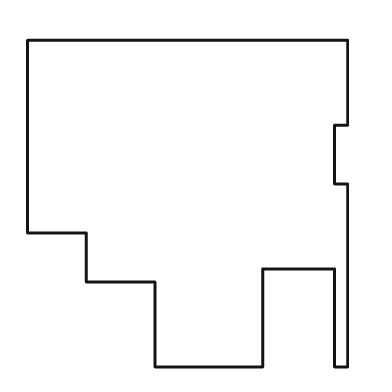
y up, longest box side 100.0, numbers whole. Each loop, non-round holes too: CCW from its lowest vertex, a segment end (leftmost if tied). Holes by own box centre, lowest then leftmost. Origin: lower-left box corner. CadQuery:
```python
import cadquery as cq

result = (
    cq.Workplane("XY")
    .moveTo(39.0, 0.0)
    .lineTo(72.0, 0.0)
    .lineTo(72.0, 30.0)
    .lineTo(94.0, 30.0)
    .lineTo(94.0, 0.0)
    .lineTo(98.0, 0.0)
    .lineTo(98.0, 56.0)
    .lineTo(94.0, 56.0)
    .lineTo(94.0, 74.0)
    .lineTo(98.0, 74.0)
    .lineTo(98.0, 100.0)
    .lineTo(0.0, 100.0)
    .lineTo(0.0, 41.0)
    .lineTo(18.0, 41.0)
    .lineTo(18.0, 26.0)
    .lineTo(39.0, 26.0)
    .close()
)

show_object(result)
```